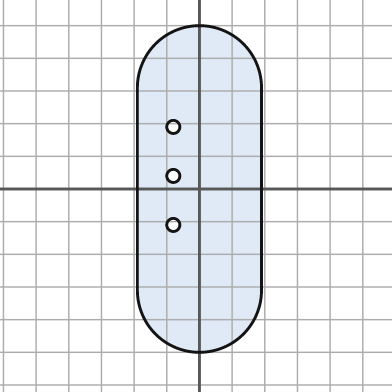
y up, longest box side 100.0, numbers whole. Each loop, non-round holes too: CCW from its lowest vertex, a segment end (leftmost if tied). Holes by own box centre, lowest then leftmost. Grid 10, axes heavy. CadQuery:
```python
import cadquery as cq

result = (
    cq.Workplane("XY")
    .moveTo(-19.0, -31.0)
    .threePointArc((0.0, -50.0), (19.0, -31.0))
    .lineTo(19.0, 31.0)
    .threePointArc((0.0, 50.0), (-19.0, 31.0))
    .close()
    .moveTo(-8.0, -11.0)
    .circle(2.0)
    .moveTo(-8.0, 4.0)
    .circle(2.0)
    .moveTo(-8.0, 19.0)
    .circle(2.0)
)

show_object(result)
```